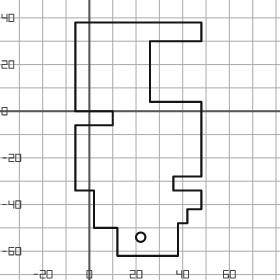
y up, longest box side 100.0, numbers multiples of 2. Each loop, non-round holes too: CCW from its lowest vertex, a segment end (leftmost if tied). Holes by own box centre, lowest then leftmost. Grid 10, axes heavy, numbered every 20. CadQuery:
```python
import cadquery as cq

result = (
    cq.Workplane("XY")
    .moveTo(12.0, -62.0)
    .lineTo(38.0, -62.0)
    .lineTo(38.0, -48.0)
    .lineTo(42.0, -48.0)
    .lineTo(42.0, -42.0)
    .lineTo(48.0, -42.0)
    .lineTo(48.0, -34.0)
    .lineTo(36.0, -34.0)
    .lineTo(36.0, -28.0)
    .lineTo(48.0, -28.0)
    .lineTo(48.0, 4.0)
    .lineTo(26.0, 4.0)
    .lineTo(26.0, 30.0)
    .lineTo(48.0, 30.0)
    .lineTo(48.0, 38.0)
    .lineTo(-6.0, 38.0)
    .lineTo(-6.0, 0.0)
    .lineTo(10.0, 0.0)
    .lineTo(10.0, -6.0)
    .lineTo(-6.0, -6.0)
    .lineTo(-6.0, -34.0)
    .lineTo(2.0, -34.0)
    .lineTo(2.0, -50.0)
    .lineTo(12.0, -50.0)
    .close()
    .moveTo(22.0, -54.0)
    .circle(2.0)
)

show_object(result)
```